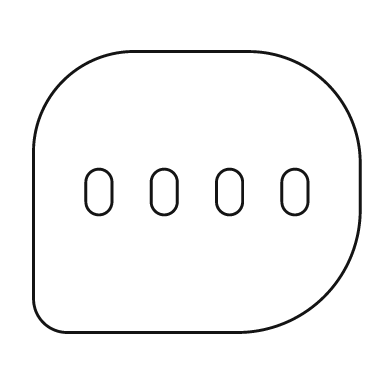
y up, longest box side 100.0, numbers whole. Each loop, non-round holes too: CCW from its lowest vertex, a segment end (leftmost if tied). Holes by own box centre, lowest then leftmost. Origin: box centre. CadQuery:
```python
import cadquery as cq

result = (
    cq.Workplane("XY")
    .moveTo(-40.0, -43.0)
    .lineTo(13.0, -43.0)
    .threePointArc((39.0, -32.0), (50.0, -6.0))
    .lineTo(50.0, 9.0)
    .threePointArc((40.0, 33.0), (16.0, 43.0))
    .lineTo(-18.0, 43.0)
    .threePointArc((-41.0, 34.0), (-50.0, 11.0))
    .lineTo(-50.0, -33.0)
    .threePointArc((-47.0, -40.0), (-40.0, -43.0))
    .close()
    .moveTo(-34.0, -3.0)
    .threePointArc((-30.0, -7.0), (-26.0, -3.0))
    .lineTo(-26.0, 3.0)
    .threePointArc((-30.0, 7.0), (-34.0, 3.0))
    .close()
    .moveTo(-14.0, -3.0)
    .threePointArc((-10.0, -7.0), (-6.0, -3.0))
    .lineTo(-6.0, 3.0)
    .threePointArc((-10.0, 7.0), (-14.0, 3.0))
    .close()
    .moveTo(6.0, -3.0)
    .threePointArc((10.0, -7.0), (14.0, -3.0))
    .lineTo(14.0, 3.0)
    .threePointArc((10.0, 7.0), (6.0, 3.0))
    .close()
    .moveTo(26.0, -3.0)
    .threePointArc((30.0, -7.0), (34.0, -3.0))
    .lineTo(34.0, 3.0)
    .threePointArc((30.0, 7.0), (26.0, 3.0))
    .close()
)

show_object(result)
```